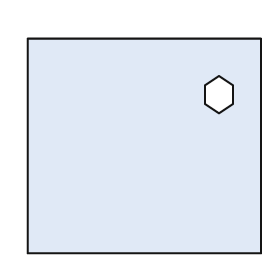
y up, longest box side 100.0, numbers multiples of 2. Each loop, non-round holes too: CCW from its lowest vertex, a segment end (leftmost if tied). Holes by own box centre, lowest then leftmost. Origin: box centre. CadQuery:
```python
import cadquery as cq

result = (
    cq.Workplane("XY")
    .moveTo(-50.0, -46.0)
    .lineTo(50.0, -46.0)
    .lineTo(50.0, 46.0)
    .lineTo(-50.0, 46.0)
    .close()
    .moveTo(32.0, 14.0)
    .lineTo(38.0, 18.0)
    .lineTo(38.0, 26.0)
    .lineTo(32.0, 30.0)
    .lineTo(26.0, 26.0)
    .lineTo(26.0, 18.0)
    .close()
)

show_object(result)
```